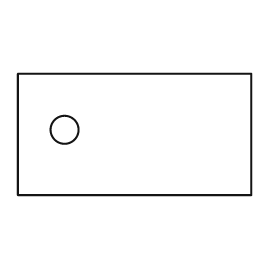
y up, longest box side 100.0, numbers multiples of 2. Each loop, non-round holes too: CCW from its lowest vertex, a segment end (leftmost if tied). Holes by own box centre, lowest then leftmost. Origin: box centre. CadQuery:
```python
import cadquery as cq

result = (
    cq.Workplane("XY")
    .moveTo(-50.0, -26.0)
    .lineTo(50.0, -26.0)
    .lineTo(50.0, 26.0)
    .lineTo(-50.0, 26.0)
    .close()
    .moveTo(-30.0, 2.0)
    .circle(6.0)
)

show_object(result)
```